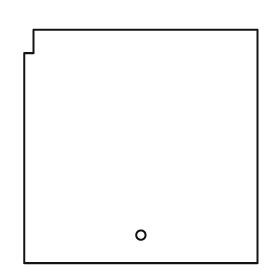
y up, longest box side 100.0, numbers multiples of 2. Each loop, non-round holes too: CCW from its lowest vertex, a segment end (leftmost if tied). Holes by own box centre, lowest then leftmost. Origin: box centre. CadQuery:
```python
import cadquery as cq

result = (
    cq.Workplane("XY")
    .moveTo(-50.0, -50.0)
    .lineTo(50.0, -50.0)
    .lineTo(50.0, 50.0)
    .lineTo(-46.0, 50.0)
    .lineTo(-46.0, 40.0)
    .lineTo(-50.0, 40.0)
    .close()
    .moveTo(0.0, -38.0)
    .circle(2.0)
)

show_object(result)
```